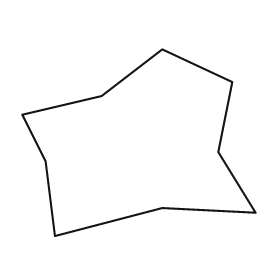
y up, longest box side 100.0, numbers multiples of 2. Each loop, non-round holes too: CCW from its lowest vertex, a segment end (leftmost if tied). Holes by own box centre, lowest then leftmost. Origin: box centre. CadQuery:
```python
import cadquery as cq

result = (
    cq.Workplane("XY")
    .moveTo(-36.0, -40.0)
    .lineTo(10.0, -28.0)
    .lineTo(50.0, -30.0)
    .lineTo(34.0, -4.0)
    .lineTo(40.0, 26.0)
    .lineTo(10.0, 40.0)
    .lineTo(-16.0, 20.0)
    .lineTo(-50.0, 12.0)
    .lineTo(-40.0, -8.0)
    .close()
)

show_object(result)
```